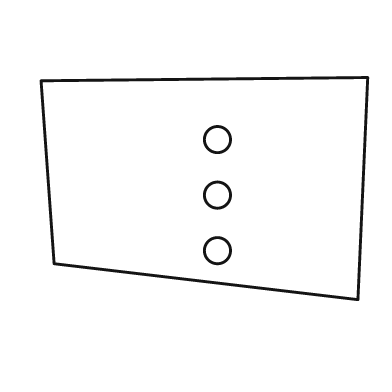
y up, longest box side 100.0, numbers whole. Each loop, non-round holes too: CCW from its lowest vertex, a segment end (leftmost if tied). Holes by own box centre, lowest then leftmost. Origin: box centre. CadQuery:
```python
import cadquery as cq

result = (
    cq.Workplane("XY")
    .moveTo(47.0, -34.0)
    .lineTo(50.0, 34.0)
    .lineTo(-50.0, 33.0)
    .lineTo(-46.0, -23.0)
    .close()
    .moveTo(4.0, -19.0)
    .circle(4.0)
    .moveTo(4.0, -2.0)
    .circle(4.0)
    .moveTo(4.0, 15.0)
    .circle(4.0)
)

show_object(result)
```